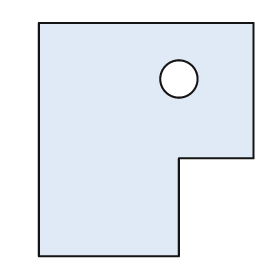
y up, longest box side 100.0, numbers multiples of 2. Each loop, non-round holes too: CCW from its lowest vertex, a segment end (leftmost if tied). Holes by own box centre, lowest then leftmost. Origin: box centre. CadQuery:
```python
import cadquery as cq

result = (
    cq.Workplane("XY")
    .moveTo(-46.0, -50.0)
    .lineTo(14.0, -50.0)
    .lineTo(14.0, -8.0)
    .lineTo(46.0, -8.0)
    .lineTo(46.0, 50.0)
    .lineTo(-46.0, 50.0)
    .close()
    .moveTo(14.0, 26.0)
    .circle(8.0)
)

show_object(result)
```